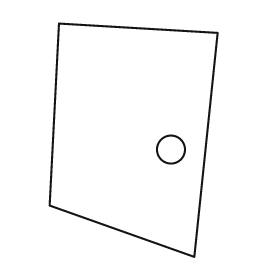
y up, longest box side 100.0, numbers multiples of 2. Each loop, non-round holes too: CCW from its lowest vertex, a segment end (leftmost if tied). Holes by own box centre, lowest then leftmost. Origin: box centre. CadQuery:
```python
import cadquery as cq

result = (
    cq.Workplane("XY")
    .moveTo(26.0, -50.0)
    .lineTo(36.0, 46.0)
    .lineTo(-32.0, 50.0)
    .lineTo(-36.0, -28.0)
    .close()
    .moveTo(16.0, -4.0)
    .circle(6.0)
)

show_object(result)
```